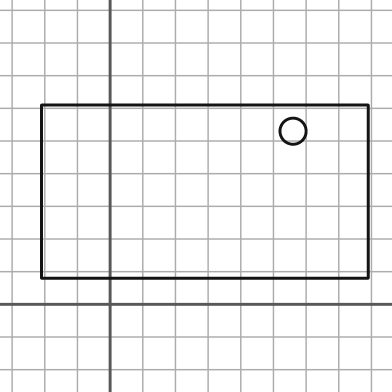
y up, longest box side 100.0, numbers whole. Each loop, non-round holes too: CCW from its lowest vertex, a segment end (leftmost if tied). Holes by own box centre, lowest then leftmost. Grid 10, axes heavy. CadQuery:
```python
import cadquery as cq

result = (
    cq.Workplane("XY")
    .moveTo(-21.0, 8.0)
    .lineTo(79.0, 8.0)
    .lineTo(79.0, 61.0)
    .lineTo(-21.0, 61.0)
    .close()
    .moveTo(56.0, 53.0)
    .circle(4.0)
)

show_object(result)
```